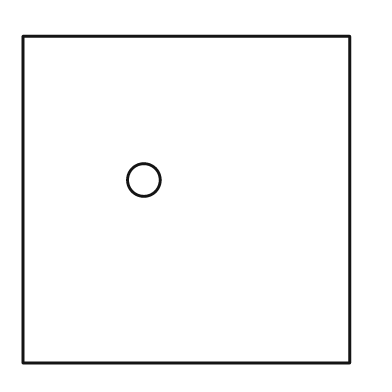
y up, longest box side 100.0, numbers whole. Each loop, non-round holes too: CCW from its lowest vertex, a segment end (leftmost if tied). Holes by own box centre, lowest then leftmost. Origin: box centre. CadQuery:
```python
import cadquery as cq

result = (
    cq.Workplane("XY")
    .moveTo(-50.0, -50.0)
    .lineTo(50.0, -50.0)
    .lineTo(50.0, 50.0)
    .lineTo(-50.0, 50.0)
    .close()
    .moveTo(-13.0, 6.0)
    .circle(5.0)
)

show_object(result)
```